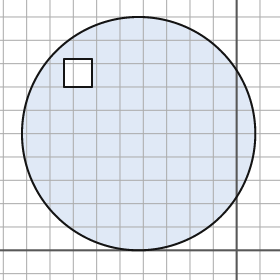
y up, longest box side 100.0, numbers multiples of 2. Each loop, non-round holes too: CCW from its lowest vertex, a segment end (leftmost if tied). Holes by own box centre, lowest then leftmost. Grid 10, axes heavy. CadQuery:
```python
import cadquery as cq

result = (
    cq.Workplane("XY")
    .moveTo(-42.0, 50.0)
    .circle(50.0)
    .moveTo(-74.0, 70.0)
    .lineTo(-62.0, 70.0)
    .lineTo(-62.0, 82.0)
    .lineTo(-74.0, 82.0)
    .close()
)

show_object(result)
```